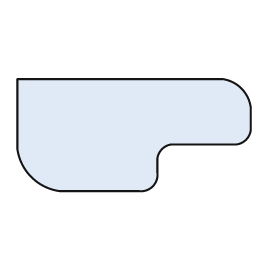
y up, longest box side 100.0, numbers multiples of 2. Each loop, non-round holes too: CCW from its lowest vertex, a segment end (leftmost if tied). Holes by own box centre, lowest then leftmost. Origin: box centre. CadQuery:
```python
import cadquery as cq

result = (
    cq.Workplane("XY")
    .moveTo(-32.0, -24.0)
    .lineTo(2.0, -24.0)
    .threePointArc((8.0, -22.0), (10.0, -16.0))
    .lineTo(10.0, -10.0)
    .threePointArc((12.0, -6.0), (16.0, -4.0))
    .lineTo(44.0, -4.0)
    .threePointArc((48.0, -2.0), (50.0, 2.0))
    .lineTo(50.0, 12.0)
    .threePointArc((46.0, 20.0), (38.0, 24.0))
    .lineTo(-50.0, 24.0)
    .lineTo(-50.0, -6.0)
    .threePointArc((-44.0, -18.0), (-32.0, -24.0))
    .close()
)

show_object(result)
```